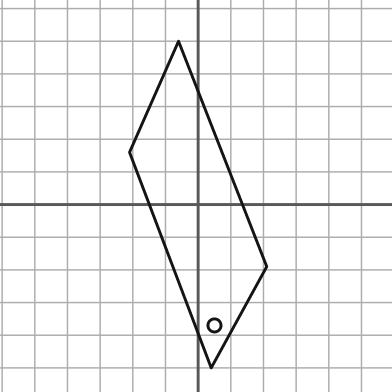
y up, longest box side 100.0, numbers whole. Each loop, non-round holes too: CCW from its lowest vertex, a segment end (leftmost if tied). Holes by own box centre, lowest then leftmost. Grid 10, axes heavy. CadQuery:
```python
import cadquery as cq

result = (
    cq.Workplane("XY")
    .moveTo(4.0, -50.0)
    .lineTo(21.0, -19.0)
    .lineTo(-6.0, 50.0)
    .lineTo(-21.0, 16.0)
    .close()
    .moveTo(5.0, -37.0)
    .circle(2.0)
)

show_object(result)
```